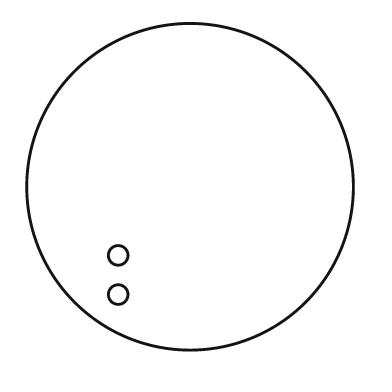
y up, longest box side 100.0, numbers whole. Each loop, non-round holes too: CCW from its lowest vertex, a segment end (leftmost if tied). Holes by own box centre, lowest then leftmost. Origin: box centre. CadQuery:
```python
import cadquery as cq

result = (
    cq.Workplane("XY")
    .moveTo(0.0, 0.0)
    .circle(50.0)
    .moveTo(-22.0, -33.0)
    .circle(3.0)
    .moveTo(-22.0, -21.0)
    .circle(3.0)
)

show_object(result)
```